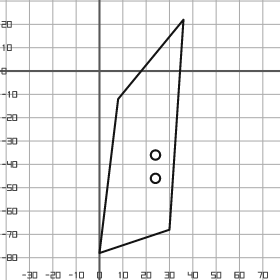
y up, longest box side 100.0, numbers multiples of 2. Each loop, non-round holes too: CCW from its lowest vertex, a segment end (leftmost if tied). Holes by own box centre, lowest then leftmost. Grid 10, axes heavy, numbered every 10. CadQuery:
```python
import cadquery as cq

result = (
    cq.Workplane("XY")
    .moveTo(0.0, -78.0)
    .lineTo(30.0, -68.0)
    .lineTo(36.0, 22.0)
    .lineTo(8.0, -12.0)
    .close()
    .moveTo(24.0, -46.0)
    .circle(2.0)
    .moveTo(24.0, -36.0)
    .circle(2.0)
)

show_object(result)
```